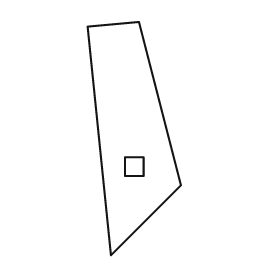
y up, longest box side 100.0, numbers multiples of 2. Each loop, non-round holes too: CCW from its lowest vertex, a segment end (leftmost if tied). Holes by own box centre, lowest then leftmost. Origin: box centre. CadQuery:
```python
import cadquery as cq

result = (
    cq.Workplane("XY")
    .moveTo(-10.0, -50.0)
    .lineTo(20.0, -20.0)
    .lineTo(2.0, 50.0)
    .lineTo(-20.0, 48.0)
    .close()
    .moveTo(-4.0, -16.0)
    .lineTo(4.0, -16.0)
    .lineTo(4.0, -8.0)
    .lineTo(-4.0, -8.0)
    .close()
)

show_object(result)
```